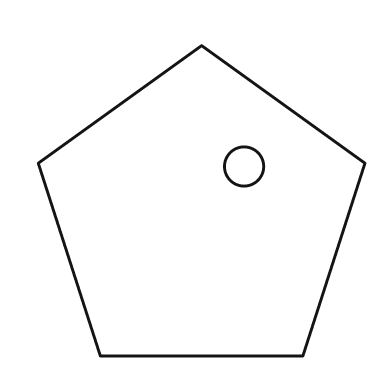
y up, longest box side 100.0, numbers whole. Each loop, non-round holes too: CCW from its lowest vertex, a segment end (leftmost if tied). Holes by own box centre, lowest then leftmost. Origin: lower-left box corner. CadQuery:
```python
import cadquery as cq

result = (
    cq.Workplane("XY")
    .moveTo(19.0, 0.0)
    .lineTo(81.0, 0.0)
    .lineTo(100.0, 59.0)
    .lineTo(50.0, 95.0)
    .lineTo(0.0, 59.0)
    .close()
    .moveTo(63.0, 58.0)
    .circle(6.0)
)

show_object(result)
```